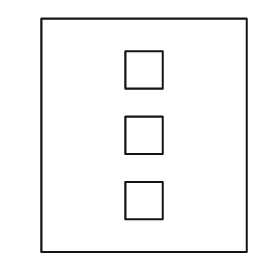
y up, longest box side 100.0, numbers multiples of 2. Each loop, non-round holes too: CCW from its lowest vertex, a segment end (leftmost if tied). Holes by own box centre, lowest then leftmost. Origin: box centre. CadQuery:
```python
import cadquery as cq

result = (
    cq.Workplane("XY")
    .moveTo(-44.0, -50.0)
    .lineTo(44.0, -50.0)
    .lineTo(44.0, 50.0)
    .lineTo(-44.0, 50.0)
    .close()
    .moveTo(-8.0, -36.0)
    .lineTo(8.0, -36.0)
    .lineTo(8.0, -20.0)
    .lineTo(-8.0, -20.0)
    .close()
    .moveTo(-8.0, -8.0)
    .lineTo(8.0, -8.0)
    .lineTo(8.0, 8.0)
    .lineTo(-8.0, 8.0)
    .close()
    .moveTo(-8.0, 20.0)
    .lineTo(8.0, 20.0)
    .lineTo(8.0, 36.0)
    .lineTo(-8.0, 36.0)
    .close()
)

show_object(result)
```